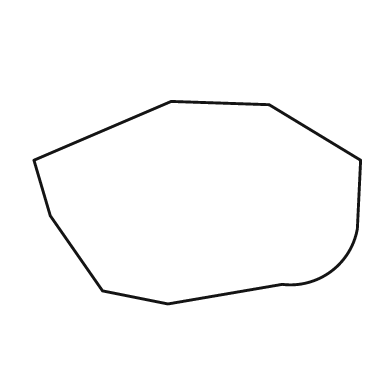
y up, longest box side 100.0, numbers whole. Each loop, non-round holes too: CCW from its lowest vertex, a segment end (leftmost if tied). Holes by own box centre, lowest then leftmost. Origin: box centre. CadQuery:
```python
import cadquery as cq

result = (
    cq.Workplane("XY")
    .moveTo(-9.0, -31.0)
    .lineTo(26.0, -25.0)
    .threePointArc((41.0, -21.0), (49.0, -8.0))
    .lineTo(50.0, 13.0)
    .lineTo(22.0, 30.0)
    .lineTo(-8.0, 31.0)
    .lineTo(-50.0, 13.0)
    .lineTo(-45.0, -4.0)
    .lineTo(-29.0, -27.0)
    .close()
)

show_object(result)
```